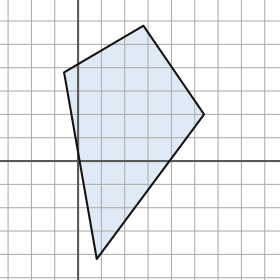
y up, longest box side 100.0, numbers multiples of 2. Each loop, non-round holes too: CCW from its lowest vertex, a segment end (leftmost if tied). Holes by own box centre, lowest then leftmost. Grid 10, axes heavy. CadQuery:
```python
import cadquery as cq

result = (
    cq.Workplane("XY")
    .moveTo(8.0, -42.0)
    .lineTo(54.0, 20.0)
    .lineTo(28.0, 58.0)
    .lineTo(-6.0, 38.0)
    .close()
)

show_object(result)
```